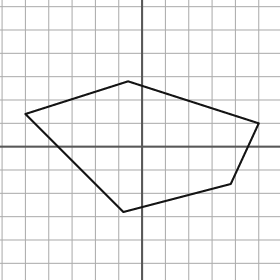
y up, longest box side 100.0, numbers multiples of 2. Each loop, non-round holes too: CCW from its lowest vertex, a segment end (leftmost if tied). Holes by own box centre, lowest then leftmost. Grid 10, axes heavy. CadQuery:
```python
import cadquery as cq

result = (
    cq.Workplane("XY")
    .moveTo(-8.0, -28.0)
    .lineTo(38.0, -16.0)
    .lineTo(50.0, 10.0)
    .lineTo(-6.0, 28.0)
    .lineTo(-50.0, 14.0)
    .close()
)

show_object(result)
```